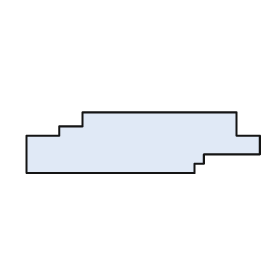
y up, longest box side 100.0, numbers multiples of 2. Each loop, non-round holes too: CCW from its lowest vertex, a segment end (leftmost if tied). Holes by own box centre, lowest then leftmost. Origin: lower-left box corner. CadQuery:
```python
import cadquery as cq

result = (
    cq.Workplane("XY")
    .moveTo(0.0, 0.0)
    .lineTo(72.0, 0.0)
    .lineTo(72.0, 4.0)
    .lineTo(76.0, 4.0)
    .lineTo(76.0, 8.0)
    .lineTo(100.0, 8.0)
    .lineTo(100.0, 16.0)
    .lineTo(90.0, 16.0)
    .lineTo(90.0, 26.0)
    .lineTo(24.0, 26.0)
    .lineTo(24.0, 20.0)
    .lineTo(14.0, 20.0)
    .lineTo(14.0, 16.0)
    .lineTo(0.0, 16.0)
    .close()
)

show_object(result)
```